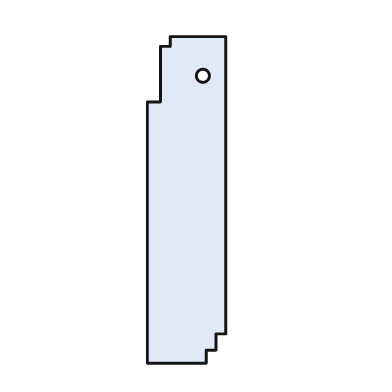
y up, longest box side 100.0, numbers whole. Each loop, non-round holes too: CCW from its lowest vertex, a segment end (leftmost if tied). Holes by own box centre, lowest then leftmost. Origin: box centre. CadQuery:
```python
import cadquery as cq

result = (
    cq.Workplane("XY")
    .moveTo(-12.0, -50.0)
    .lineTo(6.0, -50.0)
    .lineTo(6.0, -46.0)
    .lineTo(9.0, -46.0)
    .lineTo(9.0, -41.0)
    .lineTo(12.0, -41.0)
    .lineTo(12.0, 50.0)
    .lineTo(-5.0, 50.0)
    .lineTo(-5.0, 47.0)
    .lineTo(-8.0, 47.0)
    .lineTo(-8.0, 30.0)
    .lineTo(-12.0, 30.0)
    .close()
    .moveTo(5.0, 38.0)
    .circle(2.0)
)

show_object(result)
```